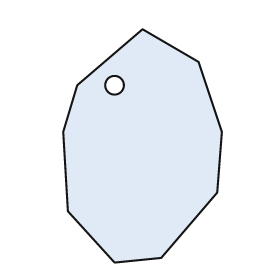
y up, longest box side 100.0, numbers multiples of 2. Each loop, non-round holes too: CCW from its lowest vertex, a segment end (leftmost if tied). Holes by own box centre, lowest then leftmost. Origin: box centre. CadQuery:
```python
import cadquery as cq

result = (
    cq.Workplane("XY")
    .moveTo(-12.0, -50.0)
    .lineTo(8.0, -48.0)
    .lineTo(32.0, -20.0)
    .lineTo(34.0, 6.0)
    .lineTo(24.0, 36.0)
    .lineTo(0.0, 50.0)
    .lineTo(-28.0, 26.0)
    .lineTo(-34.0, 6.0)
    .lineTo(-32.0, -28.0)
    .close()
    .moveTo(-12.0, 26.0)
    .circle(4.0)
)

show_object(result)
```